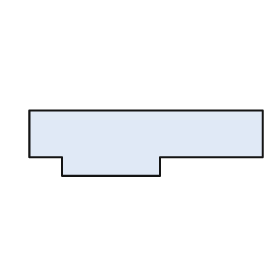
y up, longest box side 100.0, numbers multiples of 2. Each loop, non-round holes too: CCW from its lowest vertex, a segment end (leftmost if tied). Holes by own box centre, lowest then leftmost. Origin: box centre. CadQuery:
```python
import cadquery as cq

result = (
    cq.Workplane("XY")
    .moveTo(-36.0, -14.0)
    .lineTo(6.0, -14.0)
    .lineTo(6.0, -6.0)
    .lineTo(50.0, -6.0)
    .lineTo(50.0, 14.0)
    .lineTo(-50.0, 14.0)
    .lineTo(-50.0, -6.0)
    .lineTo(-36.0, -6.0)
    .close()
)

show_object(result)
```